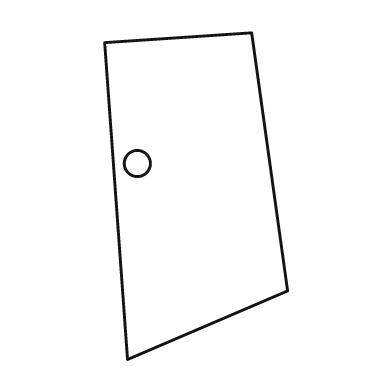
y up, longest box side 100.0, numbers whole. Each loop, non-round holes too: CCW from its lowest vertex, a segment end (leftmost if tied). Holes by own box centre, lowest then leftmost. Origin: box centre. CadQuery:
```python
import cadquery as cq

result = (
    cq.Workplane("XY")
    .moveTo(-21.0, -50.0)
    .lineTo(28.0, -29.0)
    .lineTo(17.0, 50.0)
    .lineTo(-28.0, 47.0)
    .close()
    .moveTo(-18.0, 10.0)
    .circle(4.0)
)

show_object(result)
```